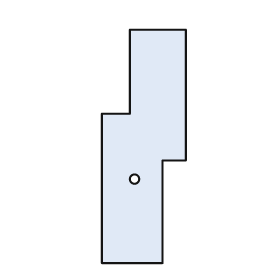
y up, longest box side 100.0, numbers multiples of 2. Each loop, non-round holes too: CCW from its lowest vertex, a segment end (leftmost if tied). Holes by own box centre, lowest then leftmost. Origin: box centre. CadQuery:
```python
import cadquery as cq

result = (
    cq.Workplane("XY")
    .moveTo(-18.0, -50.0)
    .lineTo(8.0, -50.0)
    .lineTo(8.0, -6.0)
    .lineTo(18.0, -6.0)
    .lineTo(18.0, 50.0)
    .lineTo(-6.0, 50.0)
    .lineTo(-6.0, 14.0)
    .lineTo(-18.0, 14.0)
    .close()
    .moveTo(-4.0, -14.0)
    .circle(2.0)
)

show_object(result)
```